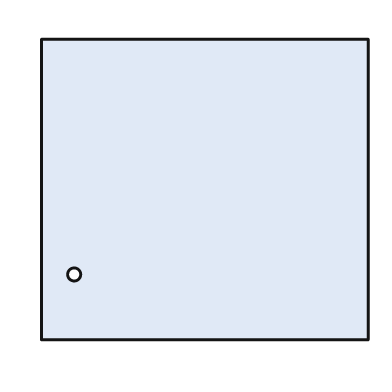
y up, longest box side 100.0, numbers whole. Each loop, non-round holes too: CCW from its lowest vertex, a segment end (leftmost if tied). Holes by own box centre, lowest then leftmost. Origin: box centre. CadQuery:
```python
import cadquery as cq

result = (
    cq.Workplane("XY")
    .moveTo(-50.0, -46.0)
    .lineTo(50.0, -46.0)
    .lineTo(50.0, 46.0)
    .lineTo(-50.0, 46.0)
    .close()
    .moveTo(-40.0, -26.0)
    .circle(2.0)
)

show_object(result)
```